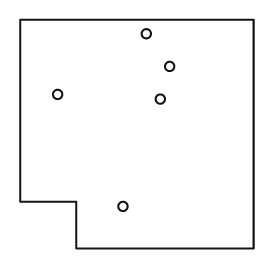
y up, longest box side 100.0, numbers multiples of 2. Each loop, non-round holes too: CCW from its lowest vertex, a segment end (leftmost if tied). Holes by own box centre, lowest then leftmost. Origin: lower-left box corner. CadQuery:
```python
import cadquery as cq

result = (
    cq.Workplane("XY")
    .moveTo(24.0, 0.0)
    .lineTo(100.0, 0.0)
    .lineTo(100.0, 98.0)
    .lineTo(0.0, 98.0)
    .lineTo(0.0, 20.0)
    .lineTo(24.0, 20.0)
    .close()
    .moveTo(44.0, 18.0)
    .circle(2.0)
    .moveTo(60.0, 64.0)
    .circle(2.0)
    .moveTo(16.0, 66.0)
    .circle(2.0)
    .moveTo(64.0, 78.0)
    .circle(2.0)
    .moveTo(54.0, 92.0)
    .circle(2.0)
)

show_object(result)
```